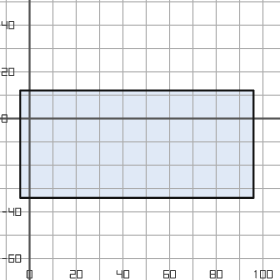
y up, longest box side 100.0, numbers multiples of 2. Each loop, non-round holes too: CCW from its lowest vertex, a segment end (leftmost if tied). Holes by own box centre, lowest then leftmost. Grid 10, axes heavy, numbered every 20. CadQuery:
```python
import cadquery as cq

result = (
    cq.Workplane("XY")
    .moveTo(-4.0, -34.0)
    .lineTo(96.0, -34.0)
    .lineTo(96.0, 12.0)
    .lineTo(-4.0, 12.0)
    .close()
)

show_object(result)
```